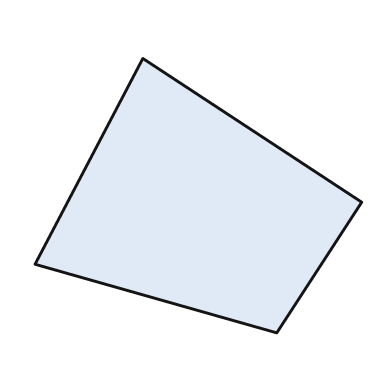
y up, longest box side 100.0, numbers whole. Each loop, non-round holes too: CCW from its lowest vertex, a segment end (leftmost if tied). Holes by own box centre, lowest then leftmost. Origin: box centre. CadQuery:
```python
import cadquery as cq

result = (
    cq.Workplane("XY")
    .moveTo(24.0, -42.0)
    .lineTo(50.0, -2.0)
    .lineTo(-17.0, 42.0)
    .lineTo(-50.0, -21.0)
    .close()
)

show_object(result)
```